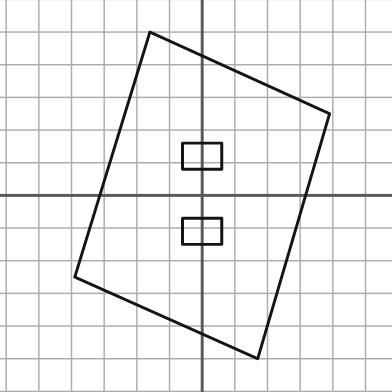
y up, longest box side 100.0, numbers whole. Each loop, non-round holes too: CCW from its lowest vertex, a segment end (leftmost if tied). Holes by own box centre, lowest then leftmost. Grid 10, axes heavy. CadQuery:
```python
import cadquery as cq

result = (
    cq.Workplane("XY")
    .moveTo(17.0, -50.0)
    .lineTo(39.0, 25.0)
    .lineTo(-16.0, 50.0)
    .lineTo(-39.0, -25.0)
    .close()
    .moveTo(-6.0, -15.0)
    .lineTo(6.0, -15.0)
    .lineTo(6.0, -7.0)
    .lineTo(-6.0, -7.0)
    .close()
    .moveTo(-6.0, 8.0)
    .lineTo(6.0, 8.0)
    .lineTo(6.0, 16.0)
    .lineTo(-6.0, 16.0)
    .close()
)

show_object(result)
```